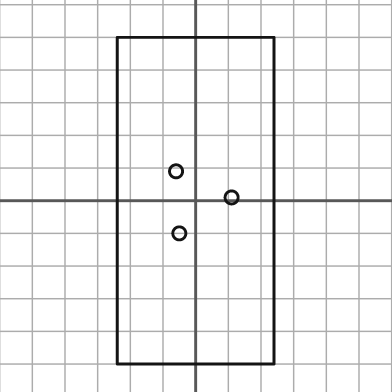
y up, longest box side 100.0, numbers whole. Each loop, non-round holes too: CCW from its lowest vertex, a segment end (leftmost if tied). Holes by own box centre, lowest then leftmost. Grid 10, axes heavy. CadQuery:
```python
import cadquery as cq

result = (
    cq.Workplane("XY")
    .moveTo(-24.0, -50.0)
    .lineTo(24.0, -50.0)
    .lineTo(24.0, 50.0)
    .lineTo(-24.0, 50.0)
    .close()
    .moveTo(-5.0, -10.0)
    .circle(2.0)
    .moveTo(11.0, 1.0)
    .circle(2.0)
    .moveTo(-6.0, 9.0)
    .circle(2.0)
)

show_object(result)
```